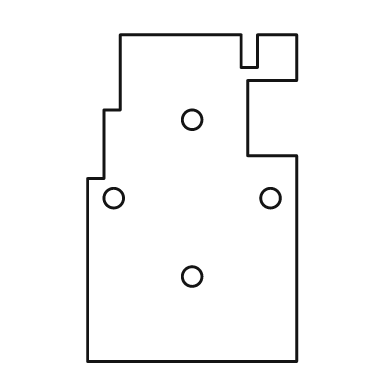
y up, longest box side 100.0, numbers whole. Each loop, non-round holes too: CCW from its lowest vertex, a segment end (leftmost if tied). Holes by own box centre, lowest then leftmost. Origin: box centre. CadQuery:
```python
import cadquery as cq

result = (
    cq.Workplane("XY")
    .moveTo(-32.0, -50.0)
    .lineTo(32.0, -50.0)
    .lineTo(32.0, 13.0)
    .lineTo(17.0, 13.0)
    .lineTo(17.0, 36.0)
    .lineTo(32.0, 36.0)
    .lineTo(32.0, 50.0)
    .lineTo(20.0, 50.0)
    .lineTo(20.0, 40.0)
    .lineTo(15.0, 40.0)
    .lineTo(15.0, 50.0)
    .lineTo(-22.0, 50.0)
    .lineTo(-22.0, 27.0)
    .lineTo(-27.0, 27.0)
    .lineTo(-27.0, 6.0)
    .lineTo(-32.0, 6.0)
    .close()
    .moveTo(0.0, -24.0)
    .circle(3.0)
    .moveTo(-24.0, 0.0)
    .circle(3.0)
    .moveTo(24.0, 0.0)
    .circle(3.0)
    .moveTo(0.0, 24.0)
    .circle(3.0)
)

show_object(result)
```